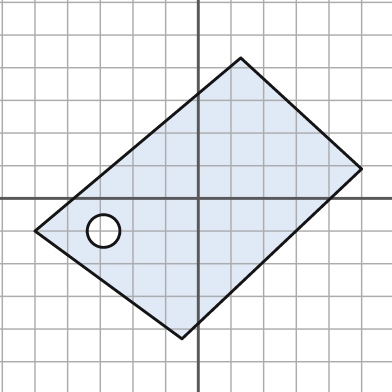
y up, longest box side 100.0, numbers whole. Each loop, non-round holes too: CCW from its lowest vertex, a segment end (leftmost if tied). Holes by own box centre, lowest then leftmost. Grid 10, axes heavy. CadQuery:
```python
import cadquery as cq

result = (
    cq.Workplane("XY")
    .moveTo(-5.0, -43.0)
    .lineTo(50.0, 9.0)
    .lineTo(13.0, 43.0)
    .lineTo(-50.0, -10.0)
    .close()
    .moveTo(-29.0, -10.0)
    .circle(5.0)
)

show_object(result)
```